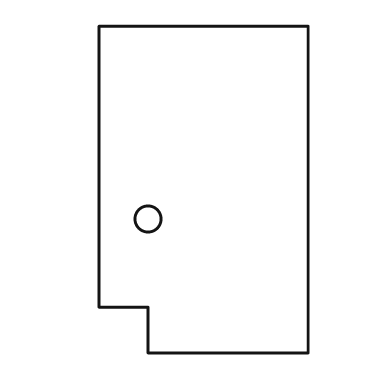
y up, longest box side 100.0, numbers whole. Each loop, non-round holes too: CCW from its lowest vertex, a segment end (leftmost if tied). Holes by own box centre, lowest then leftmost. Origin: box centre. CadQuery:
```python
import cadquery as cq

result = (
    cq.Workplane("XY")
    .moveTo(-17.0, -50.0)
    .lineTo(32.0, -50.0)
    .lineTo(32.0, 50.0)
    .lineTo(-32.0, 50.0)
    .lineTo(-32.0, -36.0)
    .lineTo(-17.0, -36.0)
    .close()
    .moveTo(-17.0, -9.0)
    .circle(4.0)
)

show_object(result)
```